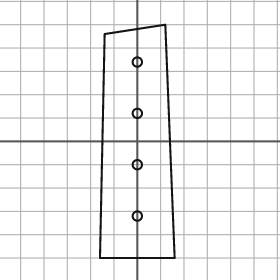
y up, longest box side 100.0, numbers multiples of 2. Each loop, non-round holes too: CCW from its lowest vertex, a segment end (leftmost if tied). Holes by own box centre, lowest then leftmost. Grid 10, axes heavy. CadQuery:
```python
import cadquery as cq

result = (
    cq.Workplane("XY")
    .moveTo(-16.0, -50.0)
    .lineTo(16.0, -50.0)
    .lineTo(12.0, 50.0)
    .lineTo(-14.0, 46.0)
    .close()
    .moveTo(0.0, -32.0)
    .circle(2.0)
    .moveTo(0.0, -10.0)
    .circle(2.0)
    .moveTo(0.0, 12.0)
    .circle(2.0)
    .moveTo(0.0, 34.0)
    .circle(2.0)
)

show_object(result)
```